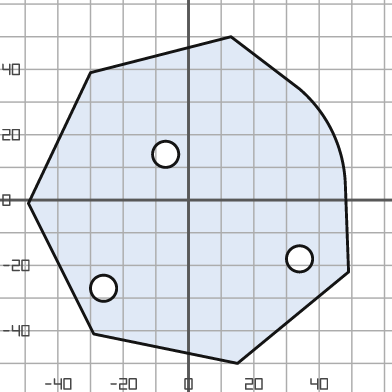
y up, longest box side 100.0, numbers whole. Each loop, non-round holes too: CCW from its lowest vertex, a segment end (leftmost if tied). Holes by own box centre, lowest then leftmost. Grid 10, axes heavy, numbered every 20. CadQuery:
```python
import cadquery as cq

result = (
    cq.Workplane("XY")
    .moveTo(15.0, -50.0)
    .lineTo(49.0, -22.0)
    .lineTo(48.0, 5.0)
    .threePointArc((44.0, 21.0), (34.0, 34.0))
    .lineTo(13.0, 50.0)
    .lineTo(-30.0, 39.0)
    .lineTo(-49.0, -1.0)
    .lineTo(-29.0, -41.0)
    .close()
    .moveTo(-26.0, -27.0)
    .circle(4.0)
    .moveTo(34.0, -18.0)
    .circle(4.0)
    .moveTo(-7.0, 14.0)
    .circle(4.0)
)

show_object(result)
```